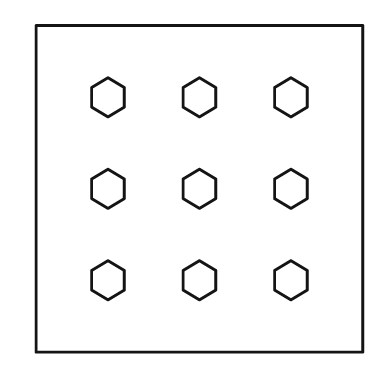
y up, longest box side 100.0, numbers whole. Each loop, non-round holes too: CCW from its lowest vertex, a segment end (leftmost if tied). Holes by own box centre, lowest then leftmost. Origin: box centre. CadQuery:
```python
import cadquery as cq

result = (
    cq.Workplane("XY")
    .moveTo(-50.0, -50.0)
    .lineTo(50.0, -50.0)
    .lineTo(50.0, 50.0)
    .lineTo(-50.0, 50.0)
    .close()
    .moveTo(-28.0, -34.0)
    .lineTo(-23.0, -31.0)
    .lineTo(-23.0, -25.0)
    .lineTo(-28.0, -22.0)
    .lineTo(-33.0, -25.0)
    .lineTo(-33.0, -31.0)
    .close()
    .moveTo(0.0, -34.0)
    .lineTo(5.0, -31.0)
    .lineTo(5.0, -25.0)
    .lineTo(0.0, -22.0)
    .lineTo(-5.0, -25.0)
    .lineTo(-5.0, -31.0)
    .close()
    .moveTo(28.0, -34.0)
    .lineTo(33.0, -31.0)
    .lineTo(33.0, -25.0)
    .lineTo(28.0, -22.0)
    .lineTo(23.0, -25.0)
    .lineTo(23.0, -31.0)
    .close()
    .moveTo(-28.0, -6.0)
    .lineTo(-23.0, -3.0)
    .lineTo(-23.0, 3.0)
    .lineTo(-28.0, 6.0)
    .lineTo(-33.0, 3.0)
    .lineTo(-33.0, -3.0)
    .close()
    .moveTo(0.0, -6.0)
    .lineTo(5.0, -3.0)
    .lineTo(5.0, 3.0)
    .lineTo(0.0, 6.0)
    .lineTo(-5.0, 3.0)
    .lineTo(-5.0, -3.0)
    .close()
    .moveTo(28.0, -6.0)
    .lineTo(33.0, -3.0)
    .lineTo(33.0, 3.0)
    .lineTo(28.0, 6.0)
    .lineTo(23.0, 3.0)
    .lineTo(23.0, -3.0)
    .close()
    .moveTo(-28.0, 22.0)
    .lineTo(-23.0, 25.0)
    .lineTo(-23.0, 31.0)
    .lineTo(-28.0, 34.0)
    .lineTo(-33.0, 31.0)
    .lineTo(-33.0, 25.0)
    .close()
    .moveTo(0.0, 22.0)
    .lineTo(5.0, 25.0)
    .lineTo(5.0, 31.0)
    .lineTo(0.0, 34.0)
    .lineTo(-5.0, 31.0)
    .lineTo(-5.0, 25.0)
    .close()
    .moveTo(28.0, 22.0)
    .lineTo(33.0, 25.0)
    .lineTo(33.0, 31.0)
    .lineTo(28.0, 34.0)
    .lineTo(23.0, 31.0)
    .lineTo(23.0, 25.0)
    .close()
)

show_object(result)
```